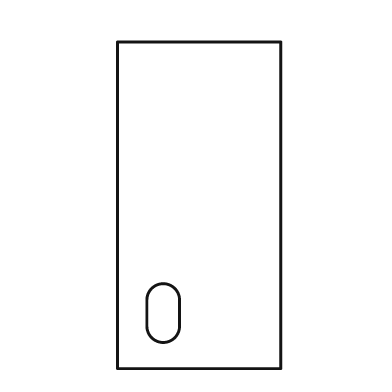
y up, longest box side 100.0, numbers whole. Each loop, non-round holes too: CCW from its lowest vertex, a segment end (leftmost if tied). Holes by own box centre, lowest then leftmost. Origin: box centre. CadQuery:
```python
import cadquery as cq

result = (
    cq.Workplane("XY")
    .moveTo(-25.0, -50.0)
    .lineTo(25.0, -50.0)
    .lineTo(25.0, 50.0)
    .lineTo(-25.0, 50.0)
    .close()
    .moveTo(-16.0, -37.0)
    .threePointArc((-11.0, -42.0), (-6.0, -37.0))
    .lineTo(-6.0, -29.0)
    .threePointArc((-11.0, -24.0), (-16.0, -29.0))
    .close()
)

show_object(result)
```